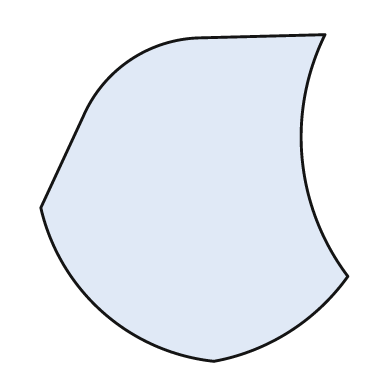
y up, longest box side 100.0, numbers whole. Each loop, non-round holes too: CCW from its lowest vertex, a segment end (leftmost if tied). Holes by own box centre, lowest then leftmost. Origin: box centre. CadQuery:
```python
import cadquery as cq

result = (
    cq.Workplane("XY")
    .moveTo(6.0, -50.0)
    .threePointArc((29.0, -41.0), (47.0, -24.0))
    .threePointArc((33.0, 12.0), (40.0, 50.0))
    .lineTo(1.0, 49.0)
    .threePointArc((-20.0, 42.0), (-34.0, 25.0))
    .lineTo(-47.0, -3.0)
    .threePointArc((-28.0, -35.0), (6.0, -50.0))
    .close()
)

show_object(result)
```